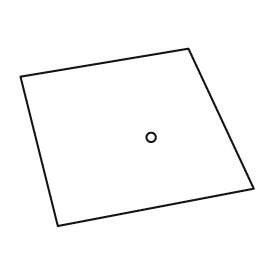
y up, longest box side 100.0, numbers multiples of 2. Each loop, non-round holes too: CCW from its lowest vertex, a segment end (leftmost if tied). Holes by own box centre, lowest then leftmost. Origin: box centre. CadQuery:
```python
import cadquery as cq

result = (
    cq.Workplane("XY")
    .moveTo(-34.0, -38.0)
    .lineTo(50.0, -22.0)
    .lineTo(22.0, 38.0)
    .lineTo(-50.0, 26.0)
    .close()
    .moveTo(6.0, 0.0)
    .circle(2.0)
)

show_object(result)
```